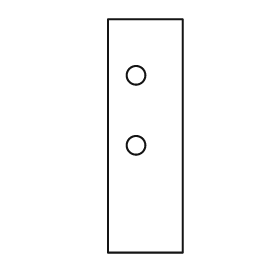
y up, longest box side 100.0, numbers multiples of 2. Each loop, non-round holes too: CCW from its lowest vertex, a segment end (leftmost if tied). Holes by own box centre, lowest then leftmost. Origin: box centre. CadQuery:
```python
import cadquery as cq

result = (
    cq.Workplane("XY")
    .moveTo(-16.0, -50.0)
    .lineTo(16.0, -50.0)
    .lineTo(16.0, 50.0)
    .lineTo(-16.0, 50.0)
    .close()
    .moveTo(-4.0, -4.0)
    .circle(4.0)
    .moveTo(-4.0, 26.0)
    .circle(4.0)
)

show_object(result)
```